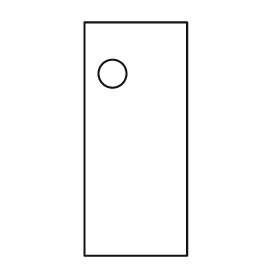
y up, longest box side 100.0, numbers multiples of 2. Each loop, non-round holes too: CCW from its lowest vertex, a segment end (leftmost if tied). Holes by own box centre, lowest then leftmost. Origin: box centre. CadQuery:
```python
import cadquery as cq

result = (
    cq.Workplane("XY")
    .moveTo(-22.0, -50.0)
    .lineTo(22.0, -50.0)
    .lineTo(22.0, 50.0)
    .lineTo(-22.0, 50.0)
    .close()
    .moveTo(-10.0, 28.0)
    .circle(6.0)
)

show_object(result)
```